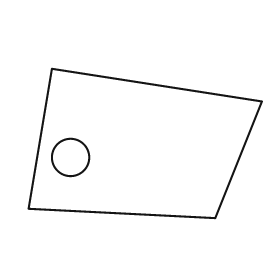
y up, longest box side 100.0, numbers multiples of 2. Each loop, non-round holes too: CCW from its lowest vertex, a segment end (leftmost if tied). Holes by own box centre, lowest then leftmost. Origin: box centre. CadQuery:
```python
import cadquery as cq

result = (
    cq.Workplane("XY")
    .moveTo(30.0, -32.0)
    .lineTo(50.0, 18.0)
    .lineTo(-40.0, 32.0)
    .lineTo(-50.0, -28.0)
    .close()
    .moveTo(-32.0, -6.0)
    .circle(8.0)
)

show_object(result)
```